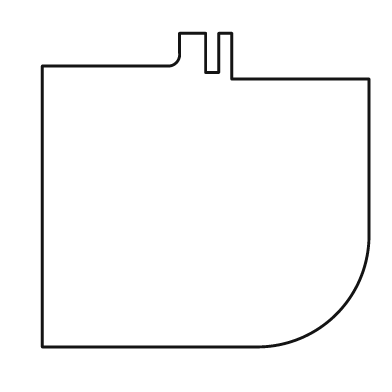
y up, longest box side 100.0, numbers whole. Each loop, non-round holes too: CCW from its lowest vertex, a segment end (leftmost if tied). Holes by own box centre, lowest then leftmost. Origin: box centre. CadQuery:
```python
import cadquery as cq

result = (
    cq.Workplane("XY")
    .moveTo(-50.0, -48.0)
    .lineTo(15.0, -48.0)
    .threePointArc((40.0, -38.0), (50.0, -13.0))
    .lineTo(50.0, 34.0)
    .lineTo(8.0, 34.0)
    .lineTo(8.0, 48.0)
    .lineTo(4.0, 48.0)
    .lineTo(4.0, 36.0)
    .lineTo(0.0, 36.0)
    .lineTo(0.0, 48.0)
    .lineTo(-8.0, 48.0)
    .lineTo(-8.0, 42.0)
    .threePointArc((-9.0, 39.0), (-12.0, 38.0))
    .lineTo(-50.0, 38.0)
    .close()
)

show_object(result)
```